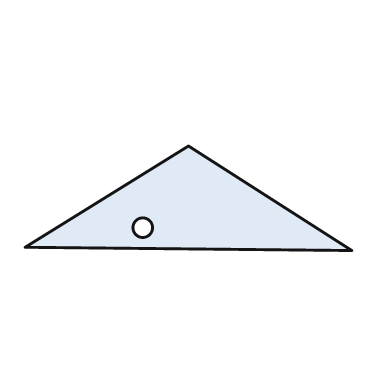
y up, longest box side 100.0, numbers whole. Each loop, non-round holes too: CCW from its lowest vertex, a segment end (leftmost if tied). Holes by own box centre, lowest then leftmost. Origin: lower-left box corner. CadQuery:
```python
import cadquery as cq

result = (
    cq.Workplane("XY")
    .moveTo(100.0, 0.0)
    .lineTo(50.0, 32.0)
    .lineTo(0.0, 1.0)
    .close()
    .moveTo(36.0, 7.0)
    .circle(3.0)
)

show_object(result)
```